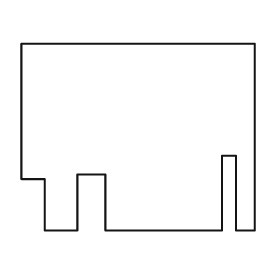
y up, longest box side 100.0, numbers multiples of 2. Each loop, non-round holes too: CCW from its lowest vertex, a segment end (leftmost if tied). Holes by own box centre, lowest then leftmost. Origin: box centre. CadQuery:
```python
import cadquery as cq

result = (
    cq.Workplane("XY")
    .moveTo(-40.0, -40.0)
    .lineTo(-26.0, -40.0)
    .lineTo(-26.0, -16.0)
    .lineTo(-14.0, -16.0)
    .lineTo(-14.0, -40.0)
    .lineTo(36.0, -40.0)
    .lineTo(36.0, -8.0)
    .lineTo(42.0, -8.0)
    .lineTo(42.0, -40.0)
    .lineTo(50.0, -40.0)
    .lineTo(50.0, 40.0)
    .lineTo(-50.0, 40.0)
    .lineTo(-50.0, -18.0)
    .lineTo(-40.0, -18.0)
    .close()
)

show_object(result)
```